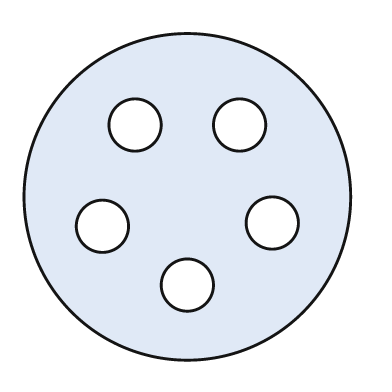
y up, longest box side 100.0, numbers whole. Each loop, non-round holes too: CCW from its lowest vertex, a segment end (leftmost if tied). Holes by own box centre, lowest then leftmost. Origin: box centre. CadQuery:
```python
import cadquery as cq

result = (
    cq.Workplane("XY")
    .moveTo(0.0, 0.0)
    .circle(50.0)
    .moveTo(0.0, -27.0)
    .circle(8.0)
    .moveTo(-26.0, -9.0)
    .circle(8.0)
    .moveTo(26.0, -8.0)
    .circle(8.0)
    .moveTo(-16.0, 22.0)
    .circle(8.0)
    .moveTo(16.0, 22.0)
    .circle(8.0)
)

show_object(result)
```